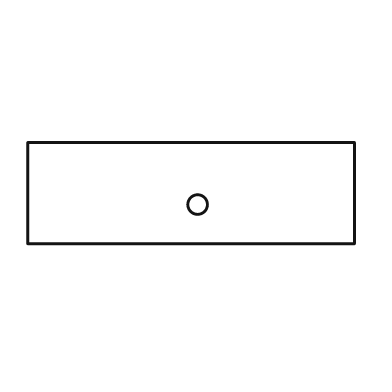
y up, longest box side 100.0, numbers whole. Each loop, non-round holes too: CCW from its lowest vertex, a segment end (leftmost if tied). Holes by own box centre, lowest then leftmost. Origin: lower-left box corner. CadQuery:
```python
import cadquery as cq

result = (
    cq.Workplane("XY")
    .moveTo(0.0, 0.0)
    .lineTo(100.0, 0.0)
    .lineTo(100.0, 31.0)
    .lineTo(0.0, 31.0)
    .close()
    .moveTo(52.0, 12.0)
    .circle(3.0)
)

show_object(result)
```